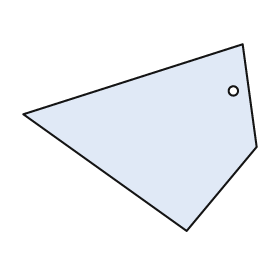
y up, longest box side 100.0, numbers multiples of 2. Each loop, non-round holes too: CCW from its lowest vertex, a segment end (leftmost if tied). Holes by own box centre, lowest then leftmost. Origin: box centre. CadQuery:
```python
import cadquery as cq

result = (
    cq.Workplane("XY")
    .moveTo(20.0, -40.0)
    .lineTo(50.0, -4.0)
    .lineTo(44.0, 40.0)
    .lineTo(-50.0, 10.0)
    .close()
    .moveTo(40.0, 20.0)
    .circle(2.0)
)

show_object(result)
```